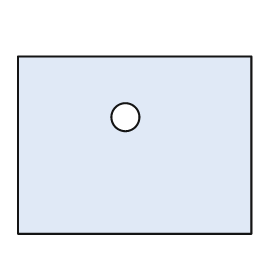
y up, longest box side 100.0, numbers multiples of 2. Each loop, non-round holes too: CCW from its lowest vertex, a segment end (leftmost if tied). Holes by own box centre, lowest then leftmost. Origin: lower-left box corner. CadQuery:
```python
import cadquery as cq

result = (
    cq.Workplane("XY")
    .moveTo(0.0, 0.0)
    .lineTo(100.0, 0.0)
    .lineTo(100.0, 76.0)
    .lineTo(0.0, 76.0)
    .close()
    .moveTo(46.0, 50.0)
    .circle(6.0)
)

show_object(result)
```